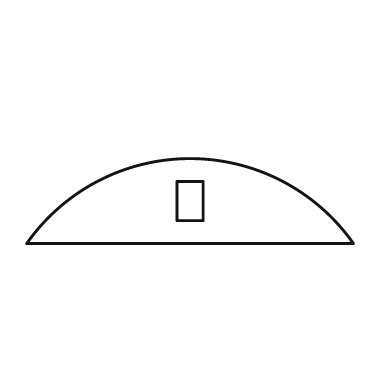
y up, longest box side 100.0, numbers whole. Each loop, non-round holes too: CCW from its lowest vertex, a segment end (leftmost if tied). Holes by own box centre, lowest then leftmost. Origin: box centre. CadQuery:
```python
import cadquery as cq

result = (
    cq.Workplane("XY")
    .moveTo(-50.0, -13.0)
    .lineTo(50.0, -13.0)
    .threePointArc((0.0, 13.0), (-50.0, -13.0))
    .close()
    .moveTo(-4.0, -6.0)
    .lineTo(4.0, -6.0)
    .lineTo(4.0, 6.0)
    .lineTo(-4.0, 6.0)
    .close()
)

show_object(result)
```